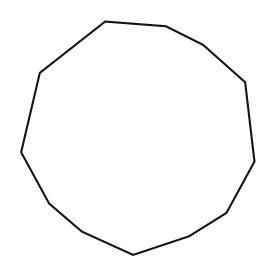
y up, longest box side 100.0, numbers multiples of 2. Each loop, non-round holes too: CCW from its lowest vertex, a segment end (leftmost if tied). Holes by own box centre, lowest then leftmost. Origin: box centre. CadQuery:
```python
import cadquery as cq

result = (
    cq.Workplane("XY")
    .moveTo(-2.0, -50.0)
    .lineTo(22.0, -42.0)
    .lineTo(38.0, -32.0)
    .lineTo(50.0, -10.0)
    .lineTo(46.0, 24.0)
    .lineTo(28.0, 40.0)
    .lineTo(12.0, 48.0)
    .lineTo(-14.0, 50.0)
    .lineTo(-42.0, 28.0)
    .lineTo(-50.0, -6.0)
    .lineTo(-38.0, -28.0)
    .lineTo(-24.0, -40.0)
    .close()
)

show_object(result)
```